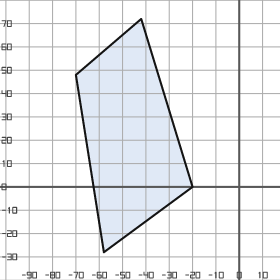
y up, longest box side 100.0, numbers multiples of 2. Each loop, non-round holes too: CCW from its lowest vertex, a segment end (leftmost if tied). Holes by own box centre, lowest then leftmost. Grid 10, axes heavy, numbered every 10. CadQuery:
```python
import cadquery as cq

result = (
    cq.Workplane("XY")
    .moveTo(-58.0, -28.0)
    .lineTo(-20.0, 0.0)
    .lineTo(-42.0, 72.0)
    .lineTo(-70.0, 48.0)
    .close()
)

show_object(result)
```